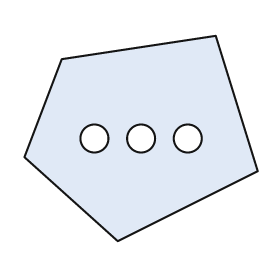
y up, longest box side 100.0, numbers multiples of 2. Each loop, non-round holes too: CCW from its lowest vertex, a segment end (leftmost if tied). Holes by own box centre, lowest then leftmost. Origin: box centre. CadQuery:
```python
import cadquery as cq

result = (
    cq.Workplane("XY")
    .moveTo(-10.0, -44.0)
    .lineTo(50.0, -14.0)
    .lineTo(32.0, 44.0)
    .lineTo(-34.0, 34.0)
    .lineTo(-50.0, -8.0)
    .close()
    .moveTo(-20.0, 0.0)
    .circle(6.0)
    .moveTo(0.0, 0.0)
    .circle(6.0)
    .moveTo(20.0, 0.0)
    .circle(6.0)
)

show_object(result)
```